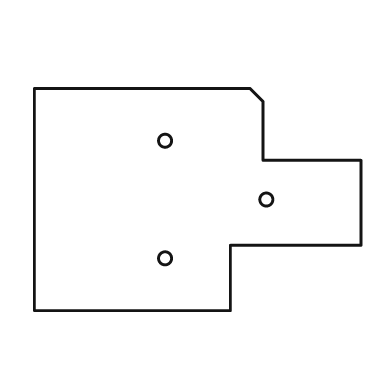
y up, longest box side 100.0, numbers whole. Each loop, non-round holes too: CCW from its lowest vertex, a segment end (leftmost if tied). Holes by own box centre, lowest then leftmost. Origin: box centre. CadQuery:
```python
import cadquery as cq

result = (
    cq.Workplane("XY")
    .moveTo(-50.0, -34.0)
    .lineTo(10.0, -34.0)
    .lineTo(10.0, -14.0)
    .lineTo(50.0, -14.0)
    .lineTo(50.0, 12.0)
    .lineTo(20.0, 12.0)
    .lineTo(20.0, 30.0)
    .lineTo(16.0, 34.0)
    .lineTo(-50.0, 34.0)
    .close()
    .moveTo(-10.0, -18.0)
    .circle(2.0)
    .moveTo(21.0, 0.0)
    .circle(2.0)
    .moveTo(-10.0, 18.0)
    .circle(2.0)
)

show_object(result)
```